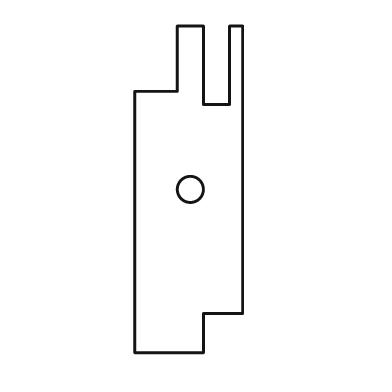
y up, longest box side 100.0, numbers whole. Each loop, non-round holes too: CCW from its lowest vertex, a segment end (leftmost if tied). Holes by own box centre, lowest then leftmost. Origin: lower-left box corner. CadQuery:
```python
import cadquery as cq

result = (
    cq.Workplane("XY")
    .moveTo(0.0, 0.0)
    .lineTo(21.0, 0.0)
    .lineTo(21.0, 12.0)
    .lineTo(33.0, 12.0)
    .lineTo(33.0, 100.0)
    .lineTo(29.0, 100.0)
    .lineTo(29.0, 76.0)
    .lineTo(21.0, 76.0)
    .lineTo(21.0, 100.0)
    .lineTo(13.0, 100.0)
    .lineTo(13.0, 80.0)
    .lineTo(0.0, 80.0)
    .close()
    .moveTo(17.0, 50.0)
    .circle(4.0)
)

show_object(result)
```